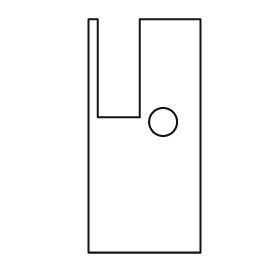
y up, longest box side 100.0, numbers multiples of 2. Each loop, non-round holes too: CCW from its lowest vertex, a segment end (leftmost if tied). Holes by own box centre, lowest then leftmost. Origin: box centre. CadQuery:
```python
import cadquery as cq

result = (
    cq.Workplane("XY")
    .moveTo(-24.0, -50.0)
    .lineTo(24.0, -50.0)
    .lineTo(24.0, 50.0)
    .lineTo(-2.0, 50.0)
    .lineTo(-2.0, 8.0)
    .lineTo(-20.0, 8.0)
    .lineTo(-20.0, 50.0)
    .lineTo(-24.0, 50.0)
    .close()
    .moveTo(8.0, 6.0)
    .circle(6.0)
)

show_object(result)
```